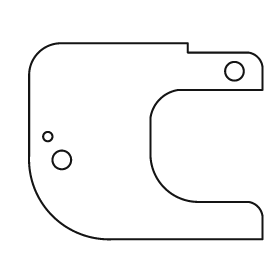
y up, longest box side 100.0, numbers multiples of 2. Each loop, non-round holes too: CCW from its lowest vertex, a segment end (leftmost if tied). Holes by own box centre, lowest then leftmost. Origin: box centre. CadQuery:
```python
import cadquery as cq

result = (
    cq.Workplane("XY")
    .moveTo(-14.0, -42.0)
    .lineTo(50.0, -42.0)
    .lineTo(50.0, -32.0)
    .threePointArc((48.0, -28.0), (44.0, -26.0))
    .lineTo(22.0, -26.0)
    .threePointArc((8.0, -20.0), (2.0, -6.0))
    .lineTo(2.0, 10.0)
    .threePointArc((6.0, 18.0), (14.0, 22.0))
    .lineTo(50.0, 22.0)
    .lineTo(50.0, 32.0)
    .threePointArc((48.0, 36.0), (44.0, 38.0))
    .lineTo(18.0, 38.0)
    .lineTo(18.0, 42.0)
    .lineTo(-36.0, 42.0)
    .threePointArc((-46.0, 38.0), (-50.0, 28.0))
    .lineTo(-50.0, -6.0)
    .threePointArc((-40.0, -32.0), (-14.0, -42.0))
    .close()
    .moveTo(-36.0, -8.0)
    .circle(4.0)
    .moveTo(-42.0, 2.0)
    .circle(2.0)
    .moveTo(38.0, 30.0)
    .circle(4.0)
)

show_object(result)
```